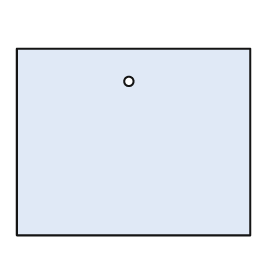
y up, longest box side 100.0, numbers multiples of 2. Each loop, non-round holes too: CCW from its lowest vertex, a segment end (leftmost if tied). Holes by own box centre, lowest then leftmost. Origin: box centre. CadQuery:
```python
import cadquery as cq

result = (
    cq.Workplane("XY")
    .moveTo(-50.0, -40.0)
    .lineTo(50.0, -40.0)
    .lineTo(50.0, 40.0)
    .lineTo(-50.0, 40.0)
    .close()
    .moveTo(-2.0, 26.0)
    .circle(2.0)
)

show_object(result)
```